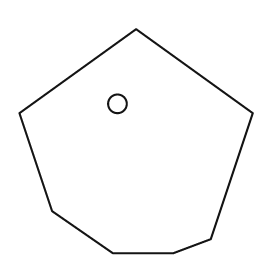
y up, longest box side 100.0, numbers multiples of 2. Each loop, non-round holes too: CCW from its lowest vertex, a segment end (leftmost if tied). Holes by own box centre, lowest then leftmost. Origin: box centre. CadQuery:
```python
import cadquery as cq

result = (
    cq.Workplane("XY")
    .moveTo(-10.0, -48.0)
    .lineTo(16.0, -48.0)
    .lineTo(32.0, -42.0)
    .lineTo(50.0, 12.0)
    .lineTo(0.0, 48.0)
    .lineTo(-50.0, 12.0)
    .lineTo(-36.0, -30.0)
    .close()
    .moveTo(-8.0, 16.0)
    .circle(4.0)
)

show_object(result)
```